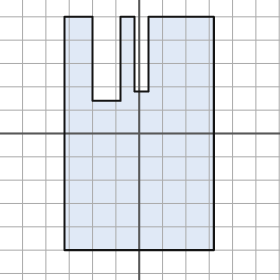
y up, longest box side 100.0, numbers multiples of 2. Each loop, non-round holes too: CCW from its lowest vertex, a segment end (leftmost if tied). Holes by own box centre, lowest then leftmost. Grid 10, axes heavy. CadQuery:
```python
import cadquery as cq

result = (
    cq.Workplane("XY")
    .moveTo(-32.0, -50.0)
    .lineTo(32.0, -50.0)
    .lineTo(32.0, 50.0)
    .lineTo(4.0, 50.0)
    .lineTo(4.0, 18.0)
    .lineTo(-2.0, 18.0)
    .lineTo(-2.0, 50.0)
    .lineTo(-8.0, 50.0)
    .lineTo(-8.0, 14.0)
    .lineTo(-20.0, 14.0)
    .lineTo(-20.0, 50.0)
    .lineTo(-32.0, 50.0)
    .close()
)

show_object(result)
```